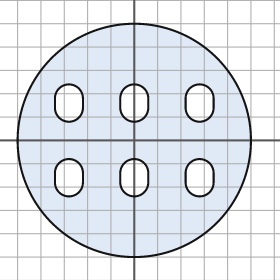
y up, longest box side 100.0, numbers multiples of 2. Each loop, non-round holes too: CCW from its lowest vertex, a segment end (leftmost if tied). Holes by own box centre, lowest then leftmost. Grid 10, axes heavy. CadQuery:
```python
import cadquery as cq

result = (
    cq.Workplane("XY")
    .moveTo(0.0, 0.0)
    .circle(50.0)
    .moveTo(-34.0, -18.0)
    .threePointArc((-28.0, -24.0), (-22.0, -18.0))
    .lineTo(-22.0, -14.0)
    .threePointArc((-28.0, -8.0), (-34.0, -14.0))
    .close()
    .moveTo(-6.0, -18.0)
    .threePointArc((0.0, -24.0), (6.0, -18.0))
    .lineTo(6.0, -14.0)
    .threePointArc((0.0, -8.0), (-6.0, -14.0))
    .close()
    .moveTo(22.0, -18.0)
    .threePointArc((28.0, -24.0), (34.0, -18.0))
    .lineTo(34.0, -14.0)
    .threePointArc((28.0, -8.0), (22.0, -14.0))
    .close()
    .moveTo(-34.0, 14.0)
    .threePointArc((-28.0, 8.0), (-22.0, 14.0))
    .lineTo(-22.0, 18.0)
    .threePointArc((-28.0, 24.0), (-34.0, 18.0))
    .close()
    .moveTo(-6.0, 14.0)
    .threePointArc((0.0, 8.0), (6.0, 14.0))
    .lineTo(6.0, 18.0)
    .threePointArc((0.0, 24.0), (-6.0, 18.0))
    .close()
    .moveTo(22.0, 14.0)
    .threePointArc((28.0, 8.0), (34.0, 14.0))
    .lineTo(34.0, 18.0)
    .threePointArc((28.0, 24.0), (22.0, 18.0))
    .close()
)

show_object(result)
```